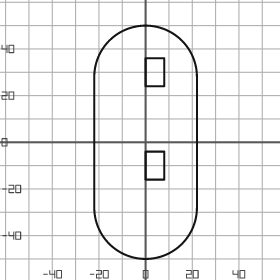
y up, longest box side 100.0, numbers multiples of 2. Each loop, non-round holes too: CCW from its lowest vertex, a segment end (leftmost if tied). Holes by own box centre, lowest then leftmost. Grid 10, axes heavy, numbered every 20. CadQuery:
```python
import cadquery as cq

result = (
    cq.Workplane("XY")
    .moveTo(-22.0, -28.0)
    .threePointArc((0.0, -50.0), (22.0, -28.0))
    .lineTo(22.0, 28.0)
    .threePointArc((0.0, 50.0), (-22.0, 28.0))
    .close()
    .moveTo(0.0, -16.0)
    .lineTo(8.0, -16.0)
    .lineTo(8.0, -4.0)
    .lineTo(0.0, -4.0)
    .close()
    .moveTo(0.0, 24.0)
    .lineTo(8.0, 24.0)
    .lineTo(8.0, 36.0)
    .lineTo(0.0, 36.0)
    .close()
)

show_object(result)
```